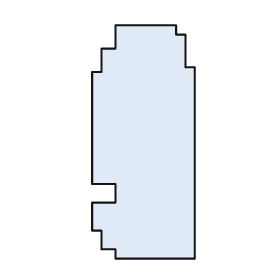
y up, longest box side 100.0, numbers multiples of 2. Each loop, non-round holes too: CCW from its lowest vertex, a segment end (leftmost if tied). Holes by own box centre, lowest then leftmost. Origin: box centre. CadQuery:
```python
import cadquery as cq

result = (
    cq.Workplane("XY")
    .moveTo(-12.0, -50.0)
    .lineTo(22.0, -50.0)
    .lineTo(22.0, 32.0)
    .lineTo(18.0, 32.0)
    .lineTo(18.0, 46.0)
    .lineTo(14.0, 46.0)
    .lineTo(14.0, 50.0)
    .lineTo(-12.0, 50.0)
    .lineTo(-12.0, 40.0)
    .lineTo(-18.0, 40.0)
    .lineTo(-18.0, 30.0)
    .lineTo(-22.0, 30.0)
    .lineTo(-22.0, -18.0)
    .lineTo(-12.0, -18.0)
    .lineTo(-12.0, -26.0)
    .lineTo(-22.0, -26.0)
    .lineTo(-22.0, -38.0)
    .lineTo(-18.0, -38.0)
    .lineTo(-18.0, -46.0)
    .lineTo(-12.0, -46.0)
    .close()
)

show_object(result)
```